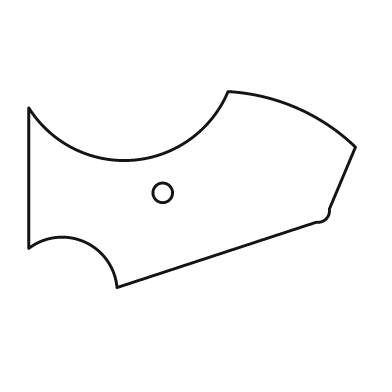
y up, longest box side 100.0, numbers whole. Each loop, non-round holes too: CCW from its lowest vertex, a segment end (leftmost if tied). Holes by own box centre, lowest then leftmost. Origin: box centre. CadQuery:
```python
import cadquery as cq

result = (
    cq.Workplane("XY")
    .moveTo(-23.0, -30.0)
    .lineTo(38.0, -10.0)
    .threePointArc((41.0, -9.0), (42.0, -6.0))
    .lineTo(50.0, 13.0)
    .threePointArc((32.0, 25.0), (11.0, 30.0))
    .threePointArc((-18.0, 9.0), (-50.0, 25.0))
    .lineTo(-50.0, -18.0)
    .threePointArc((-33.0, -16.0), (-23.0, -30.0))
    .close()
    .moveTo(-9.0, -1.0)
    .circle(3.0)
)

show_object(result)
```